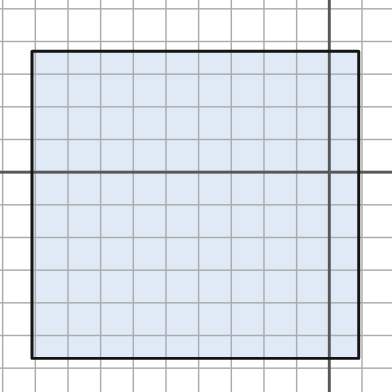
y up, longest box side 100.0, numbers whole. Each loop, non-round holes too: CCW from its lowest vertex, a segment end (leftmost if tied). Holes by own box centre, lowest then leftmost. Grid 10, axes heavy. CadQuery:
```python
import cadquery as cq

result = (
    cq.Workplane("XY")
    .moveTo(-91.0, -57.0)
    .lineTo(9.0, -57.0)
    .lineTo(9.0, 37.0)
    .lineTo(-91.0, 37.0)
    .close()
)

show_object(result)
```